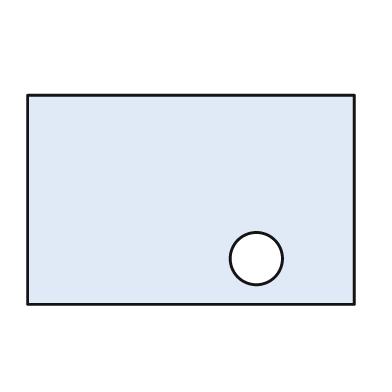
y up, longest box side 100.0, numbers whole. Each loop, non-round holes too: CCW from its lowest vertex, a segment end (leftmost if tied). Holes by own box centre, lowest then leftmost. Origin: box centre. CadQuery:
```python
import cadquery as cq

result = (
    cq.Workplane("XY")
    .moveTo(-50.0, -32.0)
    .lineTo(50.0, -32.0)
    .lineTo(50.0, 32.0)
    .lineTo(-50.0, 32.0)
    .close()
    .moveTo(20.0, -18.0)
    .circle(8.0)
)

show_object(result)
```